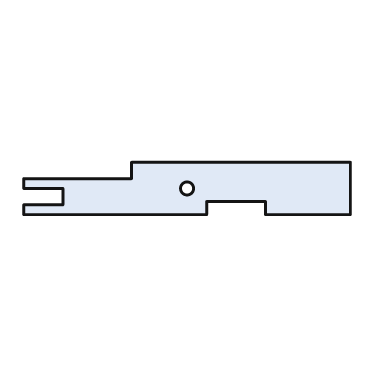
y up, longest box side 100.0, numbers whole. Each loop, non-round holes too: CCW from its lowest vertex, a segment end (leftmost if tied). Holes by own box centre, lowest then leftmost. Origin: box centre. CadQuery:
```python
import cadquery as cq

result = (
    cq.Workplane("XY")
    .moveTo(-50.0, -8.0)
    .lineTo(6.0, -8.0)
    .lineTo(6.0, -4.0)
    .lineTo(24.0, -4.0)
    .lineTo(24.0, -8.0)
    .lineTo(50.0, -8.0)
    .lineTo(50.0, 8.0)
    .lineTo(-17.0, 8.0)
    .lineTo(-17.0, 3.0)
    .lineTo(-50.0, 3.0)
    .lineTo(-50.0, 0.0)
    .lineTo(-38.0, 0.0)
    .lineTo(-38.0, -5.0)
    .lineTo(-50.0, -5.0)
    .close()
    .moveTo(0.0, 0.0)
    .circle(2.0)
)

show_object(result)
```